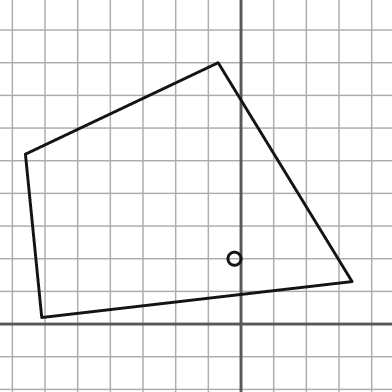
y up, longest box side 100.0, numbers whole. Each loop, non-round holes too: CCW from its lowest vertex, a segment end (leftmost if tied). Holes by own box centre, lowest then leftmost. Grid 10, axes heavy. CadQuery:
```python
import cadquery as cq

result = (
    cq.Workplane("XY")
    .moveTo(-61.0, 2.0)
    .lineTo(34.0, 13.0)
    .lineTo(-7.0, 80.0)
    .lineTo(-66.0, 52.0)
    .close()
    .moveTo(-2.0, 20.0)
    .circle(2.0)
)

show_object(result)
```